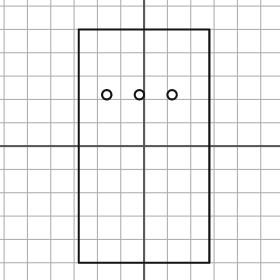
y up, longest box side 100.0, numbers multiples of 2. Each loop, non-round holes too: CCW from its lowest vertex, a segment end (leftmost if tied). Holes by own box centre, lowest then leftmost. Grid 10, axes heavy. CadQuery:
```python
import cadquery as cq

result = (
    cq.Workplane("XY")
    .moveTo(-28.0, -50.0)
    .lineTo(28.0, -50.0)
    .lineTo(28.0, 50.0)
    .lineTo(-28.0, 50.0)
    .close()
    .moveTo(-16.0, 22.0)
    .circle(2.0)
    .moveTo(-2.0, 22.0)
    .circle(2.0)
    .moveTo(12.0, 22.0)
    .circle(2.0)
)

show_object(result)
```